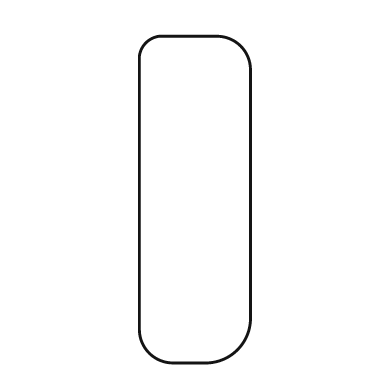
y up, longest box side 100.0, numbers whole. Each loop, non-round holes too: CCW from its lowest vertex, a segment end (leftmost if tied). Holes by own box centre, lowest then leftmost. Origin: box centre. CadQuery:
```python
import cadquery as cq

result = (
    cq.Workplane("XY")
    .moveTo(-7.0, -50.0)
    .lineTo(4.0, -50.0)
    .threePointArc((13.0, -46.0), (17.0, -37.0))
    .lineTo(17.0, 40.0)
    .threePointArc((14.0, 47.0), (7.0, 50.0))
    .lineTo(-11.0, 50.0)
    .threePointArc((-15.0, 48.0), (-17.0, 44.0))
    .lineTo(-17.0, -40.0)
    .threePointArc((-14.0, -47.0), (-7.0, -50.0))
    .close()
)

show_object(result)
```